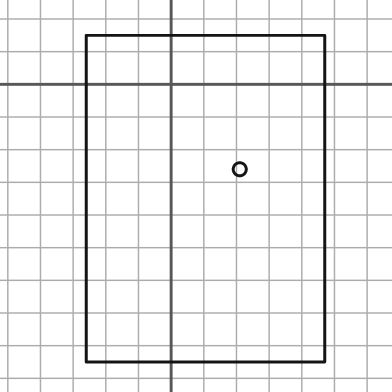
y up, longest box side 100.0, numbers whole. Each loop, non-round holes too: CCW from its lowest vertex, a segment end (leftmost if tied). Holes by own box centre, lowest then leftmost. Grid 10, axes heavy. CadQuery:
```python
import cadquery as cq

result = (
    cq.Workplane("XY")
    .moveTo(-26.0, -85.0)
    .lineTo(47.0, -85.0)
    .lineTo(47.0, 15.0)
    .lineTo(-26.0, 15.0)
    .close()
    .moveTo(21.0, -26.0)
    .circle(2.0)
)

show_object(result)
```